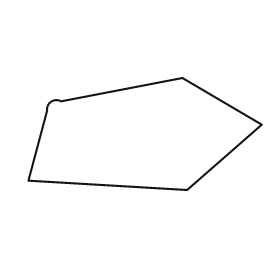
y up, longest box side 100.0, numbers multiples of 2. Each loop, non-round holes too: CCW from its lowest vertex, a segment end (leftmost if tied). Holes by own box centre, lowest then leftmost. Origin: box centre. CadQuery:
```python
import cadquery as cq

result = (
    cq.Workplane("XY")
    .moveTo(18.0, -24.0)
    .lineTo(50.0, 4.0)
    .lineTo(16.0, 24.0)
    .lineTo(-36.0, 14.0)
    .threePointArc((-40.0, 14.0), (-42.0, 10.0))
    .lineTo(-50.0, -20.0)
    .close()
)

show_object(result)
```